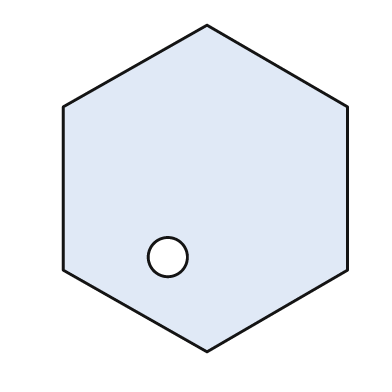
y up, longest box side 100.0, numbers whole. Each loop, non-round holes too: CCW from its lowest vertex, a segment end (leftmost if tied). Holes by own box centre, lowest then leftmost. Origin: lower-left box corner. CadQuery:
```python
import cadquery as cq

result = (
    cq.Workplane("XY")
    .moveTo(44.0, 0.0)
    .lineTo(87.0, 25.0)
    .lineTo(87.0, 75.0)
    .lineTo(44.0, 100.0)
    .lineTo(0.0, 75.0)
    .lineTo(0.0, 25.0)
    .close()
    .moveTo(32.0, 29.0)
    .circle(6.0)
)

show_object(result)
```